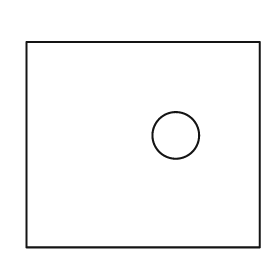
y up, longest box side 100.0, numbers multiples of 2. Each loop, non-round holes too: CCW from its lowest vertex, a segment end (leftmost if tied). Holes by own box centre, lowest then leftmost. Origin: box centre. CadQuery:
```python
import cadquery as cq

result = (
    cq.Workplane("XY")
    .moveTo(-50.0, -44.0)
    .lineTo(50.0, -44.0)
    .lineTo(50.0, 44.0)
    .lineTo(-50.0, 44.0)
    .close()
    .moveTo(14.0, 4.0)
    .circle(10.0)
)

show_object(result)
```